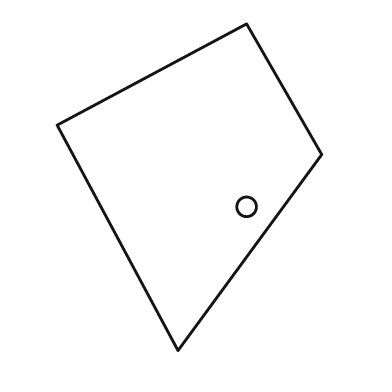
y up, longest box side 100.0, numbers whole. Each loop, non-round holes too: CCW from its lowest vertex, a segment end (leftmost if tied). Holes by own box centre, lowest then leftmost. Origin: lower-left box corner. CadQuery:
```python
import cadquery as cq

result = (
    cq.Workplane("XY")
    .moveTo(37.0, 0.0)
    .lineTo(81.0, 60.0)
    .lineTo(58.0, 100.0)
    .lineTo(0.0, 69.0)
    .close()
    .moveTo(58.0, 44.0)
    .circle(3.0)
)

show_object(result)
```